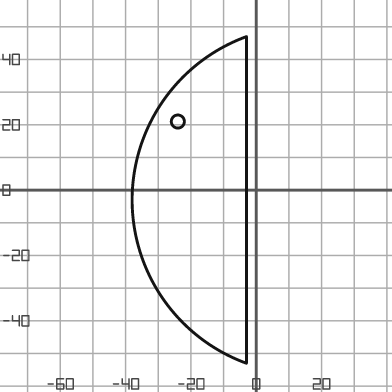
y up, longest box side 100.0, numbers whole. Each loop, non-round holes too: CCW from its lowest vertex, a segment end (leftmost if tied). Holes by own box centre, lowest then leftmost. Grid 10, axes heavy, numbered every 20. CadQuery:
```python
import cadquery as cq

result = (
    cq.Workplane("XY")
    .moveTo(-3.0, -53.0)
    .lineTo(-3.0, 47.0)
    .threePointArc((-38.0, -3.0), (-3.0, -53.0))
    .close()
    .moveTo(-24.0, 21.0)
    .circle(2.0)
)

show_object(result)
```